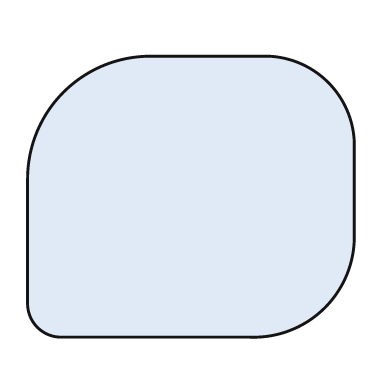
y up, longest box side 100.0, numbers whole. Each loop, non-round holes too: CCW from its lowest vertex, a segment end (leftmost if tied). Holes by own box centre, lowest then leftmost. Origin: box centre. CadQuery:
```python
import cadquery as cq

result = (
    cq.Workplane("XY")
    .moveTo(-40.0, -43.0)
    .lineTo(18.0, -43.0)
    .threePointArc((41.0, -34.0), (50.0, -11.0))
    .lineTo(50.0, 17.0)
    .threePointArc((42.0, 35.0), (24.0, 43.0))
    .lineTo(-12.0, 43.0)
    .threePointArc((-39.0, 32.0), (-50.0, 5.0))
    .lineTo(-50.0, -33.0)
    .threePointArc((-47.0, -40.0), (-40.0, -43.0))
    .close()
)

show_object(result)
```